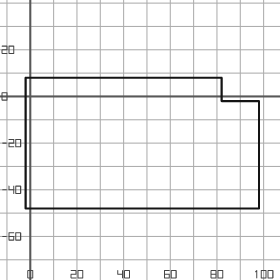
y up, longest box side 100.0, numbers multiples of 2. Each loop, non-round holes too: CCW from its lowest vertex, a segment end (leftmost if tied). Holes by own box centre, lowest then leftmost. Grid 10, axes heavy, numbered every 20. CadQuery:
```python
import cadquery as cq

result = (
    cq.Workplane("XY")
    .moveTo(-2.0, -48.0)
    .lineTo(98.0, -48.0)
    .lineTo(98.0, -2.0)
    .lineTo(82.0, -2.0)
    .lineTo(82.0, 8.0)
    .lineTo(-2.0, 8.0)
    .close()
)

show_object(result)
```